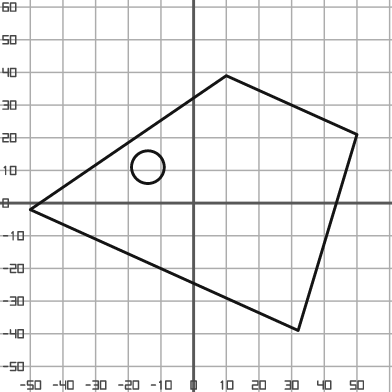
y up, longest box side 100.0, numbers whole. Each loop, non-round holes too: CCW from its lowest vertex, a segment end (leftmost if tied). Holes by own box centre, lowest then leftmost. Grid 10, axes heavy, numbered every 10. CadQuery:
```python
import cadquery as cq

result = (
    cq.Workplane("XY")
    .moveTo(32.0, -39.0)
    .lineTo(50.0, 21.0)
    .lineTo(10.0, 39.0)
    .lineTo(-50.0, -2.0)
    .close()
    .moveTo(-14.0, 11.0)
    .circle(5.0)
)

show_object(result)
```